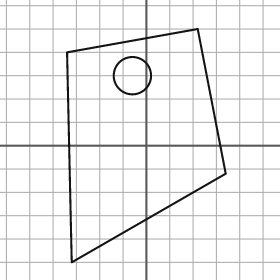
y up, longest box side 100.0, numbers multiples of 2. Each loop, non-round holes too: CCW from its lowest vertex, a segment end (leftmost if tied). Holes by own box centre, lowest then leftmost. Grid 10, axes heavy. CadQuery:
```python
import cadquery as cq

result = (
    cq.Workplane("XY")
    .moveTo(-32.0, -50.0)
    .lineTo(34.0, -12.0)
    .lineTo(22.0, 50.0)
    .lineTo(-34.0, 40.0)
    .close()
    .moveTo(-6.0, 30.0)
    .circle(8.0)
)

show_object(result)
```